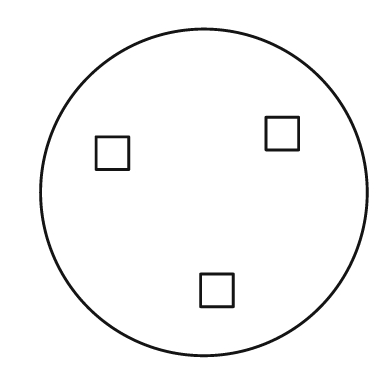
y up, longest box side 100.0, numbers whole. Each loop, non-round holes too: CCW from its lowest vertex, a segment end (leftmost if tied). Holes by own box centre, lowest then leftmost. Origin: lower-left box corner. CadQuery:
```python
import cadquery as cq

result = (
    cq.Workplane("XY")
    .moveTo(50.0, 50.0)
    .circle(50.0)
    .moveTo(49.0, 15.0)
    .lineTo(59.0, 15.0)
    .lineTo(59.0, 25.0)
    .lineTo(49.0, 25.0)
    .close()
    .moveTo(17.0, 57.0)
    .lineTo(27.0, 57.0)
    .lineTo(27.0, 67.0)
    .lineTo(17.0, 67.0)
    .close()
    .moveTo(69.0, 63.0)
    .lineTo(79.0, 63.0)
    .lineTo(79.0, 73.0)
    .lineTo(69.0, 73.0)
    .close()
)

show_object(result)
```